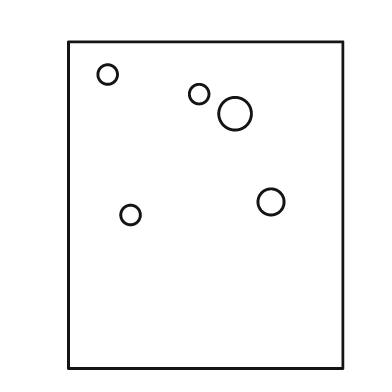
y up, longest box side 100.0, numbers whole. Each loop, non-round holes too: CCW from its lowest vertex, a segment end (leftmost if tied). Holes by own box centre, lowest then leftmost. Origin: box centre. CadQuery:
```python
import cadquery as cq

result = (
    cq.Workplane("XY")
    .moveTo(-42.0, -50.0)
    .lineTo(42.0, -50.0)
    .lineTo(42.0, 50.0)
    .lineTo(-42.0, 50.0)
    .close()
    .moveTo(-23.0, -3.0)
    .circle(3.0)
    .moveTo(20.0, 1.0)
    .circle(4.0)
    .moveTo(9.0, 28.0)
    .circle(5.0)
    .moveTo(-2.0, 34.0)
    .circle(3.0)
    .moveTo(-30.0, 40.0)
    .circle(3.0)
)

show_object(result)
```